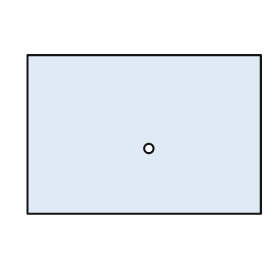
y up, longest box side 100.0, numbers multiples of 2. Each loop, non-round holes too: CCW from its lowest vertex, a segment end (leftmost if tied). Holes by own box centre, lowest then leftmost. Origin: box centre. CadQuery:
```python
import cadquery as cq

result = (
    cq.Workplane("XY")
    .moveTo(-50.0, -34.0)
    .lineTo(50.0, -34.0)
    .lineTo(50.0, 34.0)
    .lineTo(-50.0, 34.0)
    .close()
    .moveTo(2.0, -6.0)
    .circle(2.0)
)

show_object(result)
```